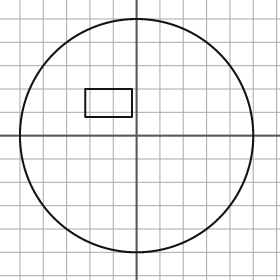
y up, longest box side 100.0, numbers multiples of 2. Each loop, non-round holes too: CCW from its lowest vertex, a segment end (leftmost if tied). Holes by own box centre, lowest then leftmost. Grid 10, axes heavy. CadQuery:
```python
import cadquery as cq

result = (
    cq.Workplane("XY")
    .moveTo(0.0, 0.0)
    .circle(50.0)
    .moveTo(-22.0, 8.0)
    .lineTo(-2.0, 8.0)
    .lineTo(-2.0, 20.0)
    .lineTo(-22.0, 20.0)
    .close()
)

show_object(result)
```